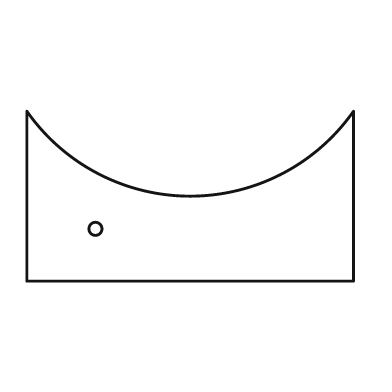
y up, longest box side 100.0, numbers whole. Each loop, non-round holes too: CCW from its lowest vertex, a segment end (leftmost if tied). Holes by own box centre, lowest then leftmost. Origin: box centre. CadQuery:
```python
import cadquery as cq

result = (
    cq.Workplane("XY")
    .moveTo(-50.0, -26.0)
    .lineTo(50.0, -26.0)
    .lineTo(50.0, 26.0)
    .threePointArc((0.0, 0.0), (-50.0, 26.0))
    .close()
    .moveTo(-29.0, -10.0)
    .circle(2.0)
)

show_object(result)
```